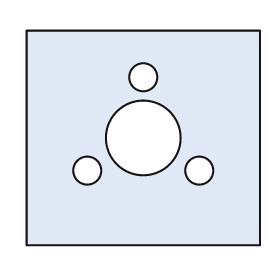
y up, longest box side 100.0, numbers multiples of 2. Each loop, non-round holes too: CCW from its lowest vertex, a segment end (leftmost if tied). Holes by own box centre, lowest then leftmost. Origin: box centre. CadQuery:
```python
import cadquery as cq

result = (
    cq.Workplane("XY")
    .moveTo(-50.0, -46.0)
    .lineTo(50.0, -46.0)
    .lineTo(50.0, 46.0)
    .lineTo(-50.0, 46.0)
    .close()
    .moveTo(-24.0, -14.0)
    .circle(6.0)
    .moveTo(24.0, -14.0)
    .circle(6.0)
    .moveTo(0.0, 0.0)
    .circle(16.0)
    .moveTo(0.0, 26.0)
    .circle(6.0)
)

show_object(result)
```